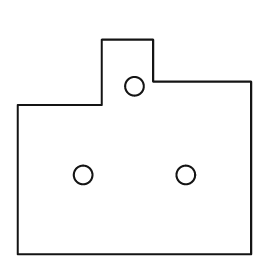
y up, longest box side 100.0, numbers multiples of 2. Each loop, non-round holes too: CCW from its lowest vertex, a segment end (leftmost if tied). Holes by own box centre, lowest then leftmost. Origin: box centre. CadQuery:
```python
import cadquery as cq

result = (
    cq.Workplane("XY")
    .moveTo(-50.0, -46.0)
    .lineTo(50.0, -46.0)
    .lineTo(50.0, 28.0)
    .lineTo(8.0, 28.0)
    .lineTo(8.0, 46.0)
    .lineTo(-14.0, 46.0)
    .lineTo(-14.0, 18.0)
    .lineTo(-50.0, 18.0)
    .close()
    .moveTo(-22.0, -12.0)
    .circle(4.0)
    .moveTo(22.0, -12.0)
    .circle(4.0)
    .moveTo(0.0, 26.0)
    .circle(4.0)
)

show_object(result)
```